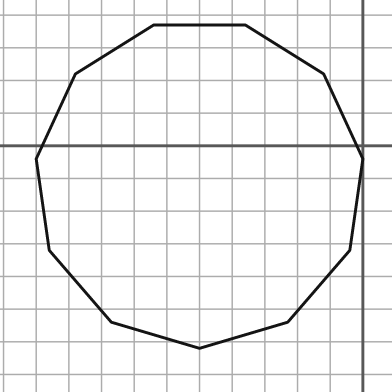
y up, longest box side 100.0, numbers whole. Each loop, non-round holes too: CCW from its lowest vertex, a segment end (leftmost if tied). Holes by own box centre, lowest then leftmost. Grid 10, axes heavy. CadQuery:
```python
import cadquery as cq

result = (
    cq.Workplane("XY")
    .moveTo(-50.0, -62.0)
    .lineTo(-23.0, -54.0)
    .lineTo(-4.0, -32.0)
    .lineTo(0.0, -4.0)
    .lineTo(-12.0, 22.0)
    .lineTo(-36.0, 37.0)
    .lineTo(-64.0, 37.0)
    .lineTo(-88.0, 22.0)
    .lineTo(-100.0, -4.0)
    .lineTo(-96.0, -32.0)
    .lineTo(-77.0, -54.0)
    .close()
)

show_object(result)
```